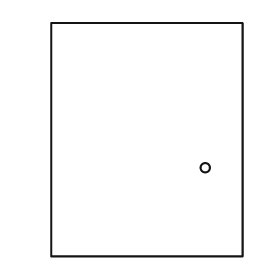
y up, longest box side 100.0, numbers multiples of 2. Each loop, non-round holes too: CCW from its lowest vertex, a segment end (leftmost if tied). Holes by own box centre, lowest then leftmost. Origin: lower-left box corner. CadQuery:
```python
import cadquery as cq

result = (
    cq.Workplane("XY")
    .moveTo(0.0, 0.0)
    .lineTo(82.0, 0.0)
    .lineTo(82.0, 100.0)
    .lineTo(0.0, 100.0)
    .close()
    .moveTo(66.0, 38.0)
    .circle(2.0)
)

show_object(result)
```